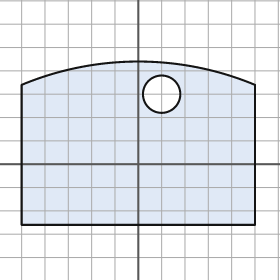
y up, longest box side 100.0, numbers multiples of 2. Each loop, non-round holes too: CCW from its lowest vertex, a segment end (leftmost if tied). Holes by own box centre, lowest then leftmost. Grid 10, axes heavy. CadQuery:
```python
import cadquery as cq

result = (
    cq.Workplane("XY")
    .moveTo(-50.0, -26.0)
    .lineTo(50.0, -26.0)
    .lineTo(50.0, 34.0)
    .threePointArc((0.0, 44.0), (-50.0, 34.0))
    .close()
    .moveTo(10.0, 30.0)
    .circle(8.0)
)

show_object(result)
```